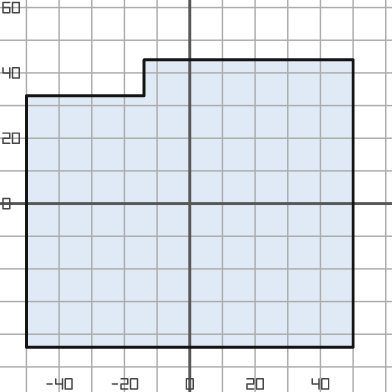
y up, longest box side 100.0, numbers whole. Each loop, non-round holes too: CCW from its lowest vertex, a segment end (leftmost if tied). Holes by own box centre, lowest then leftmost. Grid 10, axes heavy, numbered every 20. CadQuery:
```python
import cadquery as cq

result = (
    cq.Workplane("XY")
    .moveTo(-50.0, -44.0)
    .lineTo(50.0, -44.0)
    .lineTo(50.0, 44.0)
    .lineTo(-14.0, 44.0)
    .lineTo(-14.0, 33.0)
    .lineTo(-50.0, 33.0)
    .close()
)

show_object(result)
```